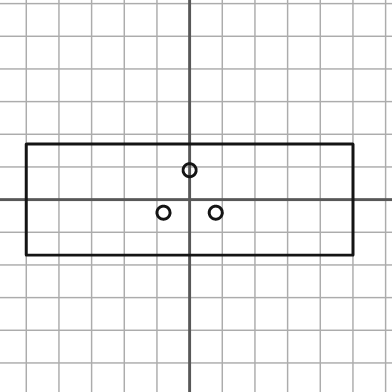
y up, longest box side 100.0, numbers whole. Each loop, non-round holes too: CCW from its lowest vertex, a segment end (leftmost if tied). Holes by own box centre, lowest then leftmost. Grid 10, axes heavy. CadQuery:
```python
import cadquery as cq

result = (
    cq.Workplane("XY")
    .moveTo(-50.0, -17.0)
    .lineTo(50.0, -17.0)
    .lineTo(50.0, 17.0)
    .lineTo(-50.0, 17.0)
    .close()
    .moveTo(-8.0, -4.0)
    .circle(2.0)
    .moveTo(8.0, -4.0)
    .circle(2.0)
    .moveTo(0.0, 9.0)
    .circle(2.0)
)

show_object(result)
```